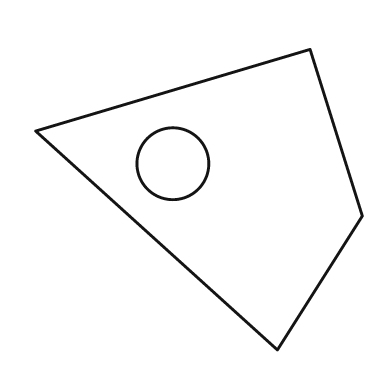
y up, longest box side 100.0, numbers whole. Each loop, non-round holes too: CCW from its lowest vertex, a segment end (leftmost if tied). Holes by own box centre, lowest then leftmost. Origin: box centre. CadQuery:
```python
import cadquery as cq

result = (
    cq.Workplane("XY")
    .moveTo(24.0, -46.0)
    .lineTo(50.0, -5.0)
    .lineTo(34.0, 46.0)
    .lineTo(-50.0, 21.0)
    .close()
    .moveTo(-8.0, 11.0)
    .circle(11.0)
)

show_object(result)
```